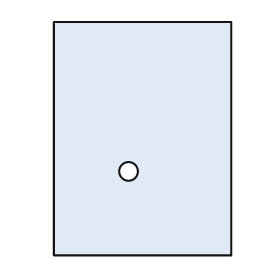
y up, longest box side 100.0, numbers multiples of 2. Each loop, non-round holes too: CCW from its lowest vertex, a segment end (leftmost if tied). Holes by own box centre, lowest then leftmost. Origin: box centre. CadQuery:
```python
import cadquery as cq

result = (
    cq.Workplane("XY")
    .moveTo(-38.0, -50.0)
    .lineTo(38.0, -50.0)
    .lineTo(38.0, 50.0)
    .lineTo(-38.0, 50.0)
    .close()
    .moveTo(-6.0, -14.0)
    .circle(4.0)
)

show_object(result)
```